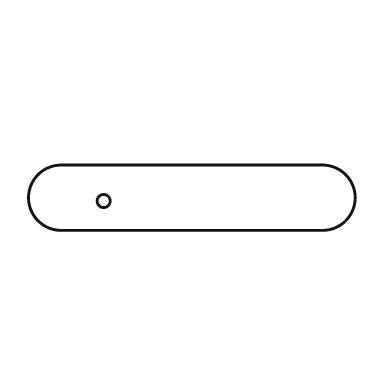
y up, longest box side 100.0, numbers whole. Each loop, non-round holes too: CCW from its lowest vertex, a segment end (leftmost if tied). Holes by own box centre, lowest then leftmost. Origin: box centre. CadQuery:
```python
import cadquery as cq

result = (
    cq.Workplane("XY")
    .moveTo(-40.0, -10.0)
    .lineTo(40.0, -10.0)
    .threePointArc((50.0, 0.0), (40.0, 10.0))
    .lineTo(-40.0, 10.0)
    .threePointArc((-50.0, 0.0), (-40.0, -10.0))
    .close()
    .moveTo(-27.0, -1.0)
    .circle(2.0)
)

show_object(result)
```